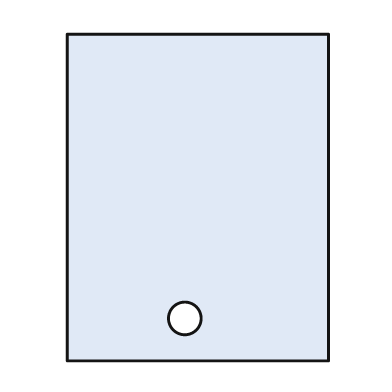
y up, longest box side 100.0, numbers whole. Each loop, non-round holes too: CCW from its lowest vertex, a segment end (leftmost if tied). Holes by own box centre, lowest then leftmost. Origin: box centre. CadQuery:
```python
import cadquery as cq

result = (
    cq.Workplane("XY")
    .moveTo(-40.0, -50.0)
    .lineTo(40.0, -50.0)
    .lineTo(40.0, 50.0)
    .lineTo(-40.0, 50.0)
    .close()
    .moveTo(-4.0, -37.0)
    .circle(5.0)
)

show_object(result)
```